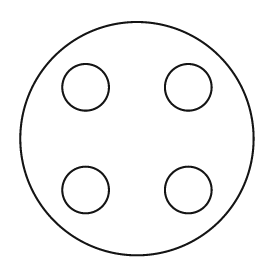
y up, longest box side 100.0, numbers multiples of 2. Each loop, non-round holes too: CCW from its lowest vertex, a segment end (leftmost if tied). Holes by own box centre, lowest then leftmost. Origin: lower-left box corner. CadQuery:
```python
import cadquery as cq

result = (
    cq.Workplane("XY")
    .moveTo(50.0, 50.0)
    .circle(50.0)
    .moveTo(28.0, 28.0)
    .circle(10.0)
    .moveTo(72.0, 28.0)
    .circle(10.0)
    .moveTo(28.0, 72.0)
    .circle(10.0)
    .moveTo(72.0, 72.0)
    .circle(10.0)
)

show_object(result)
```